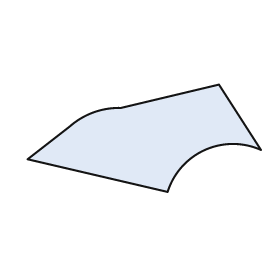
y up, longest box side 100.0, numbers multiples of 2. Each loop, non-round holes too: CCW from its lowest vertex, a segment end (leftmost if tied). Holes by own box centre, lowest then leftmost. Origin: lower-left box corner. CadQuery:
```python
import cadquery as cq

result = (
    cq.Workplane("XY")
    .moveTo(60.0, 0.0)
    .threePointArc((76.0, 18.0), (100.0, 18.0))
    .lineTo(82.0, 46.0)
    .lineTo(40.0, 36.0)
    .threePointArc((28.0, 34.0), (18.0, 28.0))
    .lineTo(0.0, 14.0)
    .close()
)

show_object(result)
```